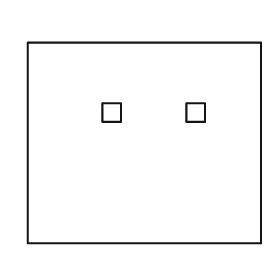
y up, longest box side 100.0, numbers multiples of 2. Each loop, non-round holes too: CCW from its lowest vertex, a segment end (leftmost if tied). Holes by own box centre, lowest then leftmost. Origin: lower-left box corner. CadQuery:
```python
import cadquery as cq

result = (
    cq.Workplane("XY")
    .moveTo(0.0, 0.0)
    .lineTo(100.0, 0.0)
    .lineTo(100.0, 86.0)
    .lineTo(0.0, 86.0)
    .close()
    .moveTo(32.0, 52.0)
    .lineTo(40.0, 52.0)
    .lineTo(40.0, 60.0)
    .lineTo(32.0, 60.0)
    .close()
    .moveTo(68.0, 52.0)
    .lineTo(76.0, 52.0)
    .lineTo(76.0, 60.0)
    .lineTo(68.0, 60.0)
    .close()
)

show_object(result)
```